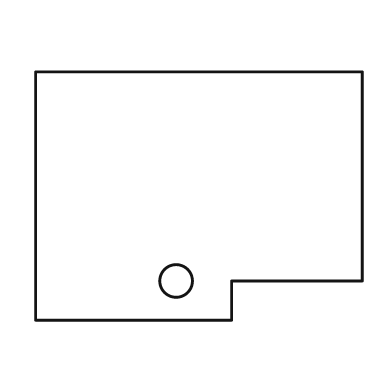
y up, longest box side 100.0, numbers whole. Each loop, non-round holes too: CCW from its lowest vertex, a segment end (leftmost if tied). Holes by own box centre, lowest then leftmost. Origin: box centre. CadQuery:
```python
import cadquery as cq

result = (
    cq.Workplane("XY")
    .moveTo(-50.0, -38.0)
    .lineTo(10.0, -38.0)
    .lineTo(10.0, -26.0)
    .lineTo(50.0, -26.0)
    .lineTo(50.0, 38.0)
    .lineTo(-50.0, 38.0)
    .close()
    .moveTo(-7.0, -26.0)
    .circle(5.0)
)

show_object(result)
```